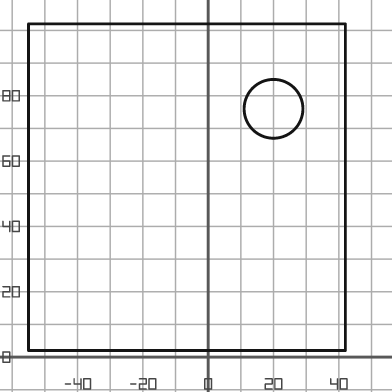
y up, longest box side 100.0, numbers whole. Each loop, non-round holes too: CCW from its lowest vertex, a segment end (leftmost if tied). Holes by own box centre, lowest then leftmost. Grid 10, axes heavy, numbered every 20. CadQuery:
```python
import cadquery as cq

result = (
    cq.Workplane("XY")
    .moveTo(-55.0, 2.0)
    .lineTo(42.0, 2.0)
    .lineTo(42.0, 102.0)
    .lineTo(-55.0, 102.0)
    .close()
    .moveTo(20.0, 76.0)
    .circle(9.0)
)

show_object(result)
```